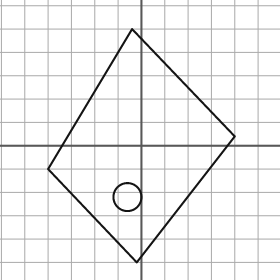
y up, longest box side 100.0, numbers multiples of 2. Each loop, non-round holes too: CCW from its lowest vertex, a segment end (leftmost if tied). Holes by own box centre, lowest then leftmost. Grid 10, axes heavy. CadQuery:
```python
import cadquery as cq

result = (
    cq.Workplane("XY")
    .moveTo(-2.0, -50.0)
    .lineTo(40.0, 4.0)
    .lineTo(-4.0, 50.0)
    .lineTo(-40.0, -10.0)
    .close()
    .moveTo(-6.0, -22.0)
    .circle(6.0)
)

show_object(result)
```